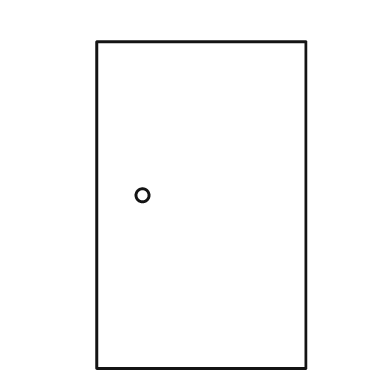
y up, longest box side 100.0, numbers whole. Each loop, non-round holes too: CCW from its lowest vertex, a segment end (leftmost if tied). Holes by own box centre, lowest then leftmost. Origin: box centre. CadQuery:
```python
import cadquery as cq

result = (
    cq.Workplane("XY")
    .moveTo(-32.0, -50.0)
    .lineTo(32.0, -50.0)
    .lineTo(32.0, 50.0)
    .lineTo(-32.0, 50.0)
    .close()
    .moveTo(-18.0, 3.0)
    .circle(2.0)
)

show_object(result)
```